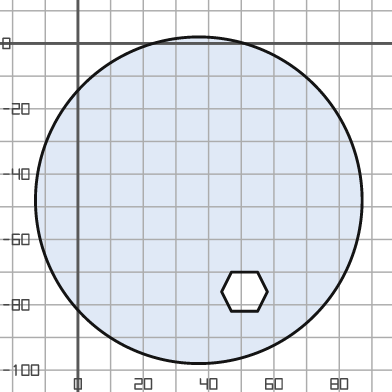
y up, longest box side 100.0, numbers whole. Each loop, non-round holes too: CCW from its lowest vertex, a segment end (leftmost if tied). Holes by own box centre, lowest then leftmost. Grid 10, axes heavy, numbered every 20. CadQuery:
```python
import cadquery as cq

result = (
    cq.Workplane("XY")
    .moveTo(37.0, -48.0)
    .circle(50.0)
    .moveTo(47.0, -82.0)
    .lineTo(55.0, -82.0)
    .lineTo(58.0, -76.0)
    .lineTo(55.0, -70.0)
    .lineTo(47.0, -70.0)
    .lineTo(44.0, -76.0)
    .close()
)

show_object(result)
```